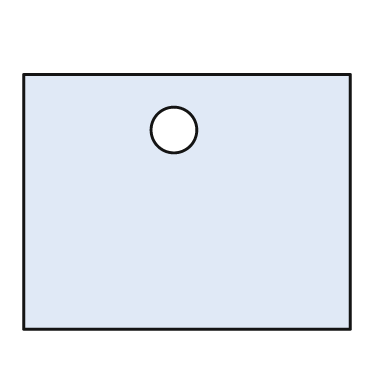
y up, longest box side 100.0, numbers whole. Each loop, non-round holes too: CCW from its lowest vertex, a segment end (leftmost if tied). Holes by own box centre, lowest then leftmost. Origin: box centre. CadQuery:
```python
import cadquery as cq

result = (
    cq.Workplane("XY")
    .moveTo(-50.0, -39.0)
    .lineTo(50.0, -39.0)
    .lineTo(50.0, 39.0)
    .lineTo(-50.0, 39.0)
    .close()
    .moveTo(-4.0, 22.0)
    .circle(7.0)
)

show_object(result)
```